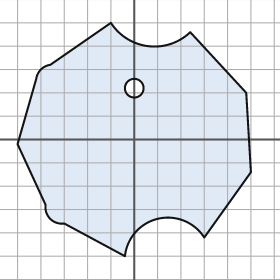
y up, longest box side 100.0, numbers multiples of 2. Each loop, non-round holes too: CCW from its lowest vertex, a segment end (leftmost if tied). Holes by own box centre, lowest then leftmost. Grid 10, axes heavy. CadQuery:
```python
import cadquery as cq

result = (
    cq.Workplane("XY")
    .moveTo(-4.0, -50.0)
    .threePointArc((10.0, -34.0), (30.0, -42.0))
    .lineTo(50.0, -14.0)
    .lineTo(48.0, 20.0)
    .lineTo(24.0, 46.0)
    .threePointArc((6.0, 40.0), (-10.0, 50.0))
    .lineTo(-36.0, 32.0)
    .threePointArc((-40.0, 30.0), (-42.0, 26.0))
    .lineTo(-50.0, -2.0)
    .lineTo(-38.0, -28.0)
    .threePointArc((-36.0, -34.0), (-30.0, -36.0))
    .close()
    .moveTo(0.0, 22.0)
    .circle(4.0)
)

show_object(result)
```